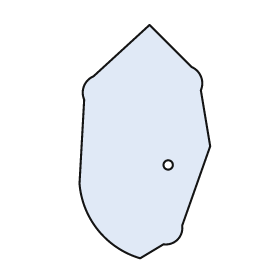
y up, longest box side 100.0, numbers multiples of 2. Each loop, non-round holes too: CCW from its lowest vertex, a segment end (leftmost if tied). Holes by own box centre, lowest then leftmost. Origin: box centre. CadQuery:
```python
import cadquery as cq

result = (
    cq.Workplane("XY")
    .moveTo(-2.0, -50.0)
    .lineTo(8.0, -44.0)
    .threePointArc((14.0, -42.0), (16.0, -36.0))
    .lineTo(28.0, -2.0)
    .lineTo(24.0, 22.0)
    .threePointArc((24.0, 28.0), (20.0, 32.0))
    .lineTo(2.0, 50.0)
    .lineTo(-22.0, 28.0)
    .threePointArc((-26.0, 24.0), (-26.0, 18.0))
    .lineTo(-28.0, -18.0)
    .threePointArc((-20.0, -38.0), (-2.0, -50.0))
    .close()
    .moveTo(10.0, -10.0)
    .circle(2.0)
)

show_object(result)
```